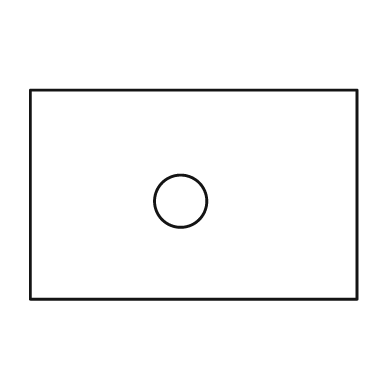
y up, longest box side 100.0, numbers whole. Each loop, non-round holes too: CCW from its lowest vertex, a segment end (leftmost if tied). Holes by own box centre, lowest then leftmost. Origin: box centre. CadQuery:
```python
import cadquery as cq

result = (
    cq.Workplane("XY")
    .moveTo(-50.0, -32.0)
    .lineTo(50.0, -32.0)
    .lineTo(50.0, 32.0)
    .lineTo(-50.0, 32.0)
    .close()
    .moveTo(-4.0, -2.0)
    .circle(8.0)
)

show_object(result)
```